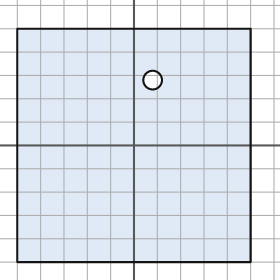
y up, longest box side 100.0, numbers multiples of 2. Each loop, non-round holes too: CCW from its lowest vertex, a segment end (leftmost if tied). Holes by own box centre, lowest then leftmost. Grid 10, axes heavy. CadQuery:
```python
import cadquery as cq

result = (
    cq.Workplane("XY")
    .moveTo(-50.0, -50.0)
    .lineTo(50.0, -50.0)
    .lineTo(50.0, 50.0)
    .lineTo(-50.0, 50.0)
    .close()
    .moveTo(8.0, 28.0)
    .circle(4.0)
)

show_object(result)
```